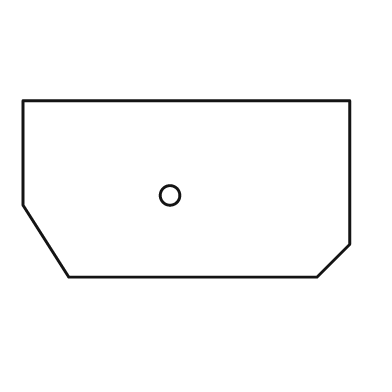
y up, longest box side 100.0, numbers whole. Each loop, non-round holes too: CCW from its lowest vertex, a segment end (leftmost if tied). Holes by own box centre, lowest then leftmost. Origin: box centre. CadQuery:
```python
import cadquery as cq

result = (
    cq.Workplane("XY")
    .moveTo(-36.0, -27.0)
    .lineTo(40.0, -27.0)
    .lineTo(50.0, -17.0)
    .lineTo(50.0, 27.0)
    .lineTo(-50.0, 27.0)
    .lineTo(-50.0, -5.0)
    .close()
    .moveTo(-5.0, -2.0)
    .circle(3.0)
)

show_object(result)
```